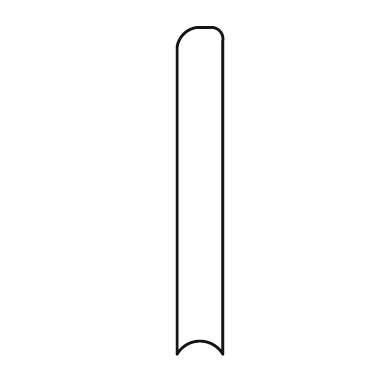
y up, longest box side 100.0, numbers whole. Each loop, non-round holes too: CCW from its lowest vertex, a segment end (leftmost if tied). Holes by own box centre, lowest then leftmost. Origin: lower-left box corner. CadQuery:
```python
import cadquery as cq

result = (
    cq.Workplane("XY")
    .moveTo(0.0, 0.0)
    .threePointArc((7.0, 4.0), (14.0, 0.0))
    .lineTo(14.0, 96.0)
    .threePointArc((13.0, 99.0), (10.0, 100.0))
    .lineTo(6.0, 100.0)
    .threePointArc((2.0, 98.0), (0.0, 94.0))
    .close()
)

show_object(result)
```